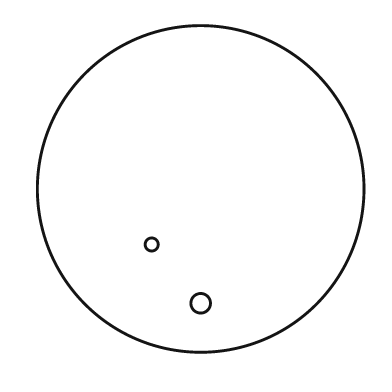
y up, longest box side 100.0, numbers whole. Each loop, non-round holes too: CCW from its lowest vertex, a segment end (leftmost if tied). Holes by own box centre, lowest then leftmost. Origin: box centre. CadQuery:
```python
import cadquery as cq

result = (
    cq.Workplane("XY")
    .moveTo(0.0, 0.0)
    .circle(50.0)
    .moveTo(0.0, -35.0)
    .circle(3.0)
    .moveTo(-15.0, -17.0)
    .circle(2.0)
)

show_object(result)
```